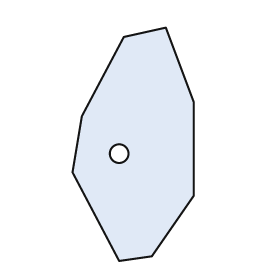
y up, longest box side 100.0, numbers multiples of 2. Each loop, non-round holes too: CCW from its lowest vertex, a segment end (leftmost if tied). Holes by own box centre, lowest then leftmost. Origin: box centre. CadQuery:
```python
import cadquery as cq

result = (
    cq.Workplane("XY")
    .moveTo(-6.0, -50.0)
    .lineTo(8.0, -48.0)
    .lineTo(26.0, -22.0)
    .lineTo(26.0, 18.0)
    .lineTo(14.0, 50.0)
    .lineTo(-4.0, 46.0)
    .lineTo(-22.0, 12.0)
    .lineTo(-26.0, -12.0)
    .close()
    .moveTo(-6.0, -4.0)
    .circle(4.0)
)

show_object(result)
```